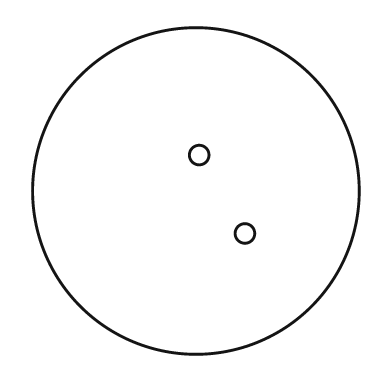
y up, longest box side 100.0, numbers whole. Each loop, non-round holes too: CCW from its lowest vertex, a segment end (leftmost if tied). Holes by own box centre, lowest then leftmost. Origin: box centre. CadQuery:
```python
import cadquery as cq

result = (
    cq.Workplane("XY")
    .moveTo(0.0, 0.0)
    .circle(50.0)
    .moveTo(15.0, -13.0)
    .circle(3.0)
    .moveTo(1.0, 11.0)
    .circle(3.0)
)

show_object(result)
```